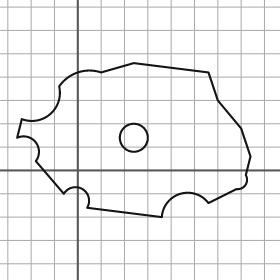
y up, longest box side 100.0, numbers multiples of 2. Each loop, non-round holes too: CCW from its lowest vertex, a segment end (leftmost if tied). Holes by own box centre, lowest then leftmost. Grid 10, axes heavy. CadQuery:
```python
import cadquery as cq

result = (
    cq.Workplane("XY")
    .moveTo(36.0, -20.0)
    .threePointArc((44.0, -10.0), (56.0, -14.0))
    .lineTo(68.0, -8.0)
    .threePointArc((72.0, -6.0), (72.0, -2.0))
    .lineTo(74.0, 6.0)
    .lineTo(70.0, 18.0)
    .lineTo(60.0, 30.0)
    .lineTo(56.0, 42.0)
    .lineTo(24.0, 46.0)
    .lineTo(10.0, 42.0)
    .threePointArc((0.0, 42.0), (-8.0, 36.0))
    .threePointArc((-12.0, 24.0), (-24.0, 22.0))
    .lineTo(-26.0, 14.0)
    .threePointArc((-18.0, 12.0), (-18.0, 4.0))
    .lineTo(-6.0, -10.0)
    .threePointArc((2.0, -8.0), (4.0, -16.0))
    .close()
    .moveTo(24.0, 14.0)
    .circle(6.0)
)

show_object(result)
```